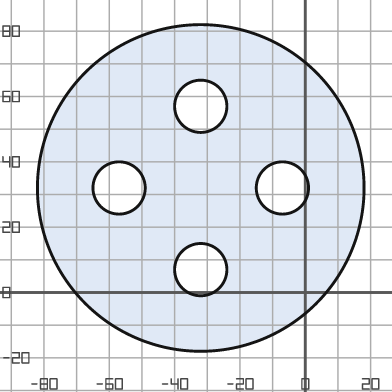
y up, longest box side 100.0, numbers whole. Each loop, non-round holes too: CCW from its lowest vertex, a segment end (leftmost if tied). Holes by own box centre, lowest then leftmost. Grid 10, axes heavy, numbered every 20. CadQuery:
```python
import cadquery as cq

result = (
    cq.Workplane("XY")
    .moveTo(-32.0, 32.0)
    .circle(50.0)
    .moveTo(-32.0, 7.0)
    .circle(8.0)
    .moveTo(-57.0, 32.0)
    .circle(8.0)
    .moveTo(-7.0, 32.0)
    .circle(8.0)
    .moveTo(-32.0, 57.0)
    .circle(8.0)
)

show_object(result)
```